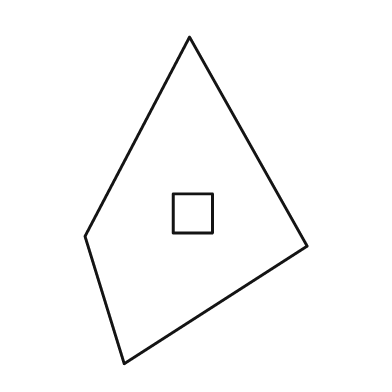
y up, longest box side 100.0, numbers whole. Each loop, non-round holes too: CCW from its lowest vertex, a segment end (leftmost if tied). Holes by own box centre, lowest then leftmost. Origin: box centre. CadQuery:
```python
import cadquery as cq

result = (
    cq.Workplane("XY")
    .moveTo(-22.0, -50.0)
    .lineTo(34.0, -14.0)
    .lineTo(-2.0, 50.0)
    .lineTo(-34.0, -11.0)
    .close()
    .moveTo(-7.0, -10.0)
    .lineTo(5.0, -10.0)
    .lineTo(5.0, 2.0)
    .lineTo(-7.0, 2.0)
    .close()
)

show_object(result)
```